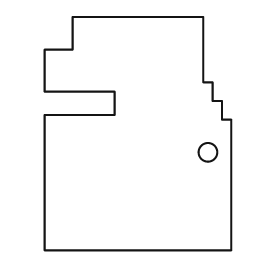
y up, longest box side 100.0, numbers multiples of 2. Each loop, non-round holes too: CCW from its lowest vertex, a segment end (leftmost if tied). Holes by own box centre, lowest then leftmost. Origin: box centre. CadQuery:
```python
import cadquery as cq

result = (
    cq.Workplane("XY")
    .moveTo(-40.0, -50.0)
    .lineTo(40.0, -50.0)
    .lineTo(40.0, 6.0)
    .lineTo(36.0, 6.0)
    .lineTo(36.0, 14.0)
    .lineTo(32.0, 14.0)
    .lineTo(32.0, 22.0)
    .lineTo(28.0, 22.0)
    .lineTo(28.0, 50.0)
    .lineTo(-28.0, 50.0)
    .lineTo(-28.0, 36.0)
    .lineTo(-40.0, 36.0)
    .lineTo(-40.0, 18.0)
    .lineTo(-10.0, 18.0)
    .lineTo(-10.0, 8.0)
    .lineTo(-40.0, 8.0)
    .close()
    .moveTo(30.0, -8.0)
    .circle(4.0)
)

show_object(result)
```